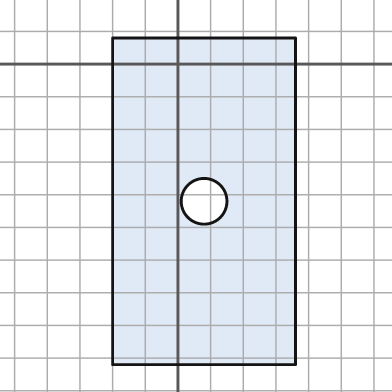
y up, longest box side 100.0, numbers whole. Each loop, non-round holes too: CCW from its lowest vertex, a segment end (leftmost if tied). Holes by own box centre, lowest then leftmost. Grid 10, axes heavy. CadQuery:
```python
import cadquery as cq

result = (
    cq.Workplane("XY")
    .moveTo(-20.0, -92.0)
    .lineTo(36.0, -92.0)
    .lineTo(36.0, 8.0)
    .lineTo(-20.0, 8.0)
    .close()
    .moveTo(8.0, -42.0)
    .circle(7.0)
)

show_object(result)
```